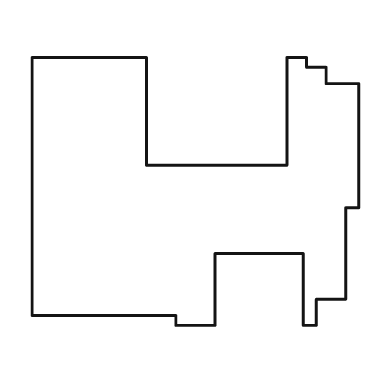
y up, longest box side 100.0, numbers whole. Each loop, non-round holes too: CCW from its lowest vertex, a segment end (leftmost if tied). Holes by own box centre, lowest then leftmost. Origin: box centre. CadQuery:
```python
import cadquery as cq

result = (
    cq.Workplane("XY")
    .moveTo(-6.0, -41.0)
    .lineTo(6.0, -41.0)
    .lineTo(6.0, -19.0)
    .lineTo(33.0, -19.0)
    .lineTo(33.0, -41.0)
    .lineTo(37.0, -41.0)
    .lineTo(37.0, -33.0)
    .lineTo(46.0, -33.0)
    .lineTo(46.0, -5.0)
    .lineTo(50.0, -5.0)
    .lineTo(50.0, 33.0)
    .lineTo(40.0, 33.0)
    .lineTo(40.0, 38.0)
    .lineTo(34.0, 38.0)
    .lineTo(34.0, 41.0)
    .lineTo(28.0, 41.0)
    .lineTo(28.0, 8.0)
    .lineTo(-15.0, 8.0)
    .lineTo(-15.0, 41.0)
    .lineTo(-50.0, 41.0)
    .lineTo(-50.0, -38.0)
    .lineTo(-6.0, -38.0)
    .close()
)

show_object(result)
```